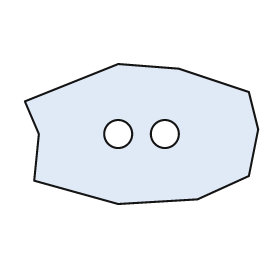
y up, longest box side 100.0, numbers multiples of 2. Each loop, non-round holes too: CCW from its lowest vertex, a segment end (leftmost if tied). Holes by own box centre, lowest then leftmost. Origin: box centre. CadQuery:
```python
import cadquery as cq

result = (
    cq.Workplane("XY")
    .moveTo(-10.0, -30.0)
    .lineTo(24.0, -28.0)
    .lineTo(46.0, -18.0)
    .lineTo(50.0, 2.0)
    .lineTo(46.0, 18.0)
    .lineTo(16.0, 28.0)
    .lineTo(-10.0, 30.0)
    .lineTo(-50.0, 14.0)
    .lineTo(-44.0, 0.0)
    .lineTo(-46.0, -20.0)
    .close()
    .moveTo(-10.0, 0.0)
    .circle(6.0)
    .moveTo(10.0, 0.0)
    .circle(6.0)
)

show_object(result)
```